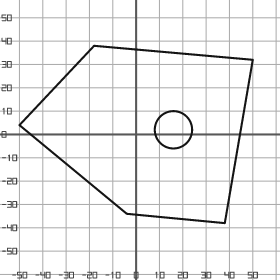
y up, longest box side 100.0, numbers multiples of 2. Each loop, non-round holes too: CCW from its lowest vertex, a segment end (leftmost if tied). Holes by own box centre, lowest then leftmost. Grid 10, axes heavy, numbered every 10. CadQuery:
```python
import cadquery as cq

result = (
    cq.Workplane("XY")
    .moveTo(38.0, -38.0)
    .lineTo(50.0, 32.0)
    .lineTo(-18.0, 38.0)
    .lineTo(-50.0, 4.0)
    .lineTo(-4.0, -34.0)
    .close()
    .moveTo(16.0, 2.0)
    .circle(8.0)
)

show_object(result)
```